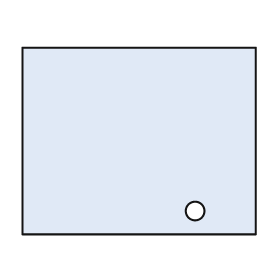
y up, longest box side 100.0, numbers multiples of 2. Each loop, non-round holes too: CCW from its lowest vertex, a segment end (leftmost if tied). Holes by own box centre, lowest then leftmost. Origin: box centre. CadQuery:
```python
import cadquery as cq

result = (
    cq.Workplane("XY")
    .moveTo(-50.0, -40.0)
    .lineTo(50.0, -40.0)
    .lineTo(50.0, 40.0)
    .lineTo(-50.0, 40.0)
    .close()
    .moveTo(24.0, -30.0)
    .circle(4.0)
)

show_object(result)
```